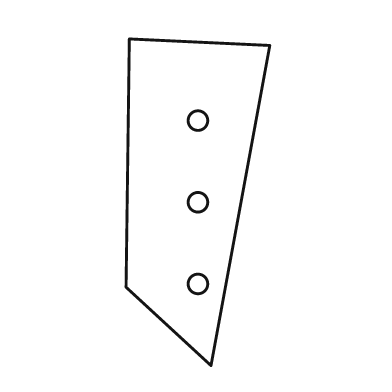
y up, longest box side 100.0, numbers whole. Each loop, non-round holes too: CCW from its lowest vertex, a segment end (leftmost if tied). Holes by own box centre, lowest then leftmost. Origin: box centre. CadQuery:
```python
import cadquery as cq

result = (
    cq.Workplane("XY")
    .moveTo(4.0, -50.0)
    .lineTo(22.0, 48.0)
    .lineTo(-21.0, 50.0)
    .lineTo(-22.0, -26.0)
    .close()
    .moveTo(0.0, -25.0)
    .circle(3.0)
    .moveTo(0.0, 0.0)
    .circle(3.0)
    .moveTo(0.0, 25.0)
    .circle(3.0)
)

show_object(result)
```